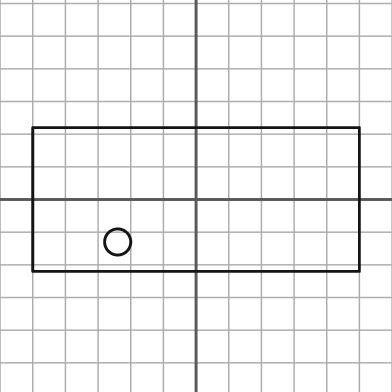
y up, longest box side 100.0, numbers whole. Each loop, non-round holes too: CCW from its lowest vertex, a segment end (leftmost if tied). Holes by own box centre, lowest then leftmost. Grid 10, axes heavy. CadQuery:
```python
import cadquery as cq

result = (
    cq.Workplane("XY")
    .moveTo(-50.0, -22.0)
    .lineTo(50.0, -22.0)
    .lineTo(50.0, 22.0)
    .lineTo(-50.0, 22.0)
    .close()
    .moveTo(-24.0, -13.0)
    .circle(4.0)
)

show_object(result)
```